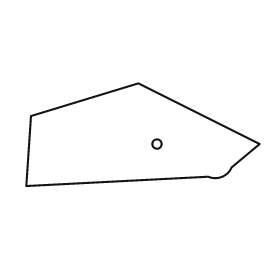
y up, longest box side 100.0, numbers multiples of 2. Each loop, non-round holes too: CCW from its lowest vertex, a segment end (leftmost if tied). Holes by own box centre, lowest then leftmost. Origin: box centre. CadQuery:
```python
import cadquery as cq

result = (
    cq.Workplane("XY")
    .moveTo(-50.0, -22.0)
    .lineTo(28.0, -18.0)
    .threePointArc((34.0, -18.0), (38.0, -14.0))
    .lineTo(50.0, -4.0)
    .lineTo(-2.0, 22.0)
    .lineTo(-48.0, 8.0)
    .close()
    .moveTo(6.0, -4.0)
    .circle(2.0)
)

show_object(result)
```